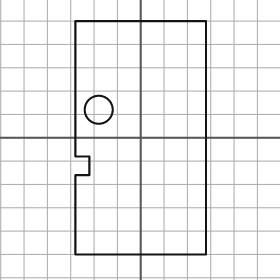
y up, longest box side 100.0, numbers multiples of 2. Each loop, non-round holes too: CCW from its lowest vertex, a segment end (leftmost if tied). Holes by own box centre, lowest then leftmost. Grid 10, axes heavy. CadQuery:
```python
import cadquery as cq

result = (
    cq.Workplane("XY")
    .moveTo(-28.0, -50.0)
    .lineTo(28.0, -50.0)
    .lineTo(28.0, 50.0)
    .lineTo(-28.0, 50.0)
    .lineTo(-28.0, -8.0)
    .lineTo(-22.0, -8.0)
    .lineTo(-22.0, -16.0)
    .lineTo(-28.0, -16.0)
    .close()
    .moveTo(-18.0, 12.0)
    .circle(6.0)
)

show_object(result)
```